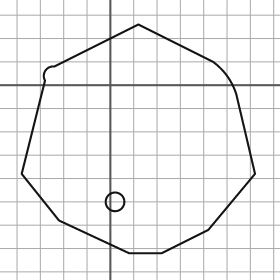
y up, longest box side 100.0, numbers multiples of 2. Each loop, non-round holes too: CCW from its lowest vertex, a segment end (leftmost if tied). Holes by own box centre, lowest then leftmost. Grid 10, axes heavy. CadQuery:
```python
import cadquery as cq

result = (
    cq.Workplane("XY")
    .moveTo(8.0, -72.0)
    .lineTo(22.0, -72.0)
    .lineTo(42.0, -62.0)
    .lineTo(62.0, -38.0)
    .lineTo(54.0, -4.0)
    .threePointArc((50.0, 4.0), (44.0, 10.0))
    .lineTo(12.0, 26.0)
    .lineTo(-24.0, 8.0)
    .threePointArc((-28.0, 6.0), (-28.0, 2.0))
    .lineTo(-38.0, -38.0)
    .lineTo(-22.0, -58.0)
    .close()
    .moveTo(2.0, -50.0)
    .circle(4.0)
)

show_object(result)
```